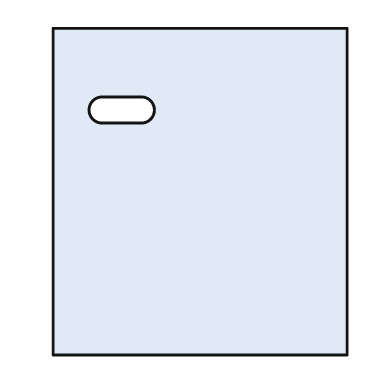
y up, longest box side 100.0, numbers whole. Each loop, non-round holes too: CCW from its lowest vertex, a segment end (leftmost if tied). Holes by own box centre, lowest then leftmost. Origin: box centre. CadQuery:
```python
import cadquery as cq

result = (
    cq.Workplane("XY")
    .moveTo(-45.0, -50.0)
    .lineTo(45.0, -50.0)
    .lineTo(45.0, 50.0)
    .lineTo(-45.0, 50.0)
    .close()
    .moveTo(-30.0, 21.0)
    .lineTo(-18.0, 21.0)
    .threePointArc((-14.0, 25.0), (-18.0, 29.0))
    .lineTo(-30.0, 29.0)
    .threePointArc((-34.0, 25.0), (-30.0, 21.0))
    .close()
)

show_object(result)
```